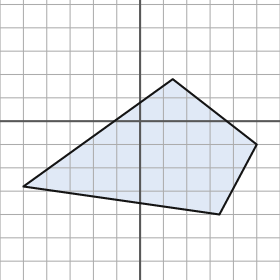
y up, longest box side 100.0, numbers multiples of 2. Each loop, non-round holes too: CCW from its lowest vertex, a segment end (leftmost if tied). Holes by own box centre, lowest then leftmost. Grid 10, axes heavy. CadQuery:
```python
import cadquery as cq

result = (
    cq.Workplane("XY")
    .moveTo(34.0, -40.0)
    .lineTo(50.0, -10.0)
    .lineTo(14.0, 18.0)
    .lineTo(-50.0, -28.0)
    .close()
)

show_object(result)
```